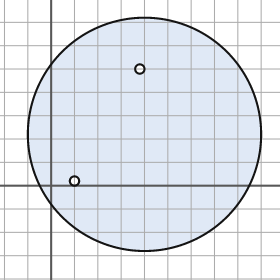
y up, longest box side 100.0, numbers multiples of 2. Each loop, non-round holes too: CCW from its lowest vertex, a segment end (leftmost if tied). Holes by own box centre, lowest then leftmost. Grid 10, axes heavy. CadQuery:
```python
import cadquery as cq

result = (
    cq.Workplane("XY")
    .moveTo(40.0, 22.0)
    .circle(50.0)
    .moveTo(10.0, 2.0)
    .circle(2.0)
    .moveTo(38.0, 50.0)
    .circle(2.0)
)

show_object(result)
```